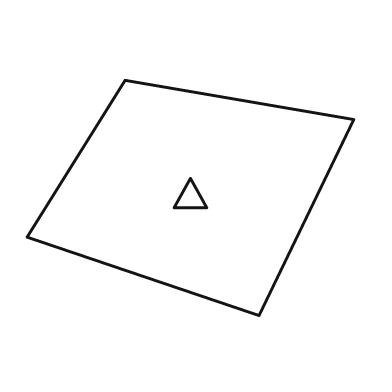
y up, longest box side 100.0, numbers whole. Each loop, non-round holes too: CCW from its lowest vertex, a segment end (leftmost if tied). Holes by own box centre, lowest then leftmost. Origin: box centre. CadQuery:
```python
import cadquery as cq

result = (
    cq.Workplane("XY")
    .moveTo(21.0, -36.0)
    .lineTo(50.0, 24.0)
    .lineTo(-20.0, 36.0)
    .lineTo(-50.0, -12.0)
    .close()
    .moveTo(-5.0, -3.0)
    .lineTo(5.0, -3.0)
    .lineTo(0.0, 6.0)
    .close()
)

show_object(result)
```